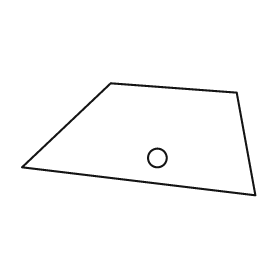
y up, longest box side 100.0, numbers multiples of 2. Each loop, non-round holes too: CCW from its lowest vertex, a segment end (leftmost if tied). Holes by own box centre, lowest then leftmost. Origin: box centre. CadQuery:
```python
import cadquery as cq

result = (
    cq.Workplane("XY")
    .moveTo(50.0, -24.0)
    .lineTo(42.0, 20.0)
    .lineTo(-12.0, 24.0)
    .lineTo(-50.0, -12.0)
    .close()
    .moveTo(8.0, -8.0)
    .circle(4.0)
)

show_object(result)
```